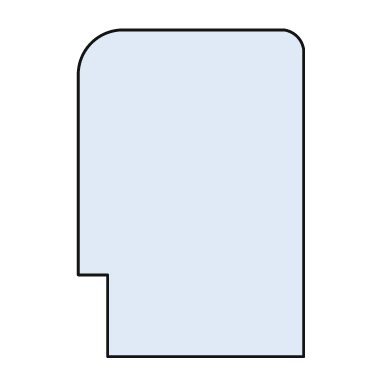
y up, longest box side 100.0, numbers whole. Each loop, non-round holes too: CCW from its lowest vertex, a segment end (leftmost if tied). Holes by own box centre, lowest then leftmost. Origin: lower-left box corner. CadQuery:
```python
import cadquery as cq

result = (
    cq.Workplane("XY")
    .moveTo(9.0, 0.0)
    .lineTo(69.0, 0.0)
    .lineTo(69.0, 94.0)
    .threePointArc((67.0, 98.0), (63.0, 100.0))
    .lineTo(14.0, 100.0)
    .threePointArc((4.0, 96.0), (0.0, 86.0))
    .lineTo(0.0, 25.0)
    .lineTo(9.0, 25.0)
    .close()
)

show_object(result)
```